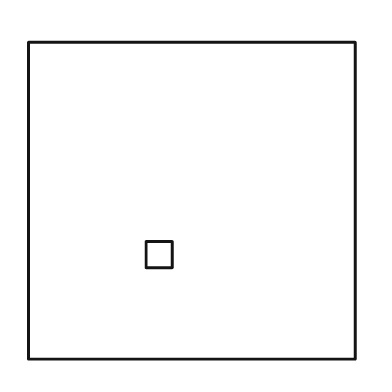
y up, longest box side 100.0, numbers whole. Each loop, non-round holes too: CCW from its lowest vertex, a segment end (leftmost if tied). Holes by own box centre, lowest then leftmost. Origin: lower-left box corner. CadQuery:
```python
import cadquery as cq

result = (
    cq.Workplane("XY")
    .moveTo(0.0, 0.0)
    .lineTo(100.0, 0.0)
    .lineTo(100.0, 97.0)
    .lineTo(0.0, 97.0)
    .close()
    .moveTo(36.0, 28.0)
    .lineTo(44.0, 28.0)
    .lineTo(44.0, 36.0)
    .lineTo(36.0, 36.0)
    .close()
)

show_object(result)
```